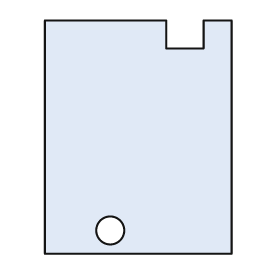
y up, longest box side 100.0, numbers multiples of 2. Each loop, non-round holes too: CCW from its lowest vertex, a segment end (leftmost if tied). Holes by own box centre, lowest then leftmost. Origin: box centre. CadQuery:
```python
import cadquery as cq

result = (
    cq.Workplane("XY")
    .moveTo(-40.0, -50.0)
    .lineTo(40.0, -50.0)
    .lineTo(40.0, 50.0)
    .lineTo(28.0, 50.0)
    .lineTo(28.0, 38.0)
    .lineTo(12.0, 38.0)
    .lineTo(12.0, 50.0)
    .lineTo(-40.0, 50.0)
    .close()
    .moveTo(-12.0, -40.0)
    .circle(6.0)
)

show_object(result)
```